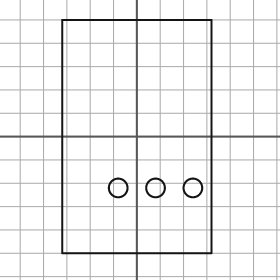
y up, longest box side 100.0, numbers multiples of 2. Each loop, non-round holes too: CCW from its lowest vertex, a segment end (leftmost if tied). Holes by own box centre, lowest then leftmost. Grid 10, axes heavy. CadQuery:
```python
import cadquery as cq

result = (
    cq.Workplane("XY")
    .moveTo(-32.0, -50.0)
    .lineTo(32.0, -50.0)
    .lineTo(32.0, 50.0)
    .lineTo(-32.0, 50.0)
    .close()
    .moveTo(-8.0, -22.0)
    .circle(4.0)
    .moveTo(8.0, -22.0)
    .circle(4.0)
    .moveTo(24.0, -22.0)
    .circle(4.0)
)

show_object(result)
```